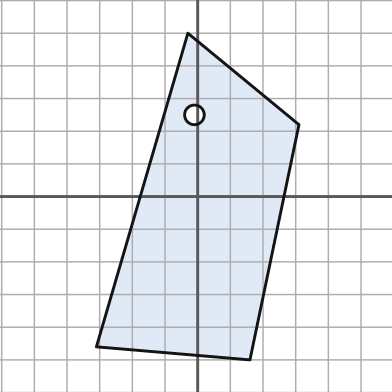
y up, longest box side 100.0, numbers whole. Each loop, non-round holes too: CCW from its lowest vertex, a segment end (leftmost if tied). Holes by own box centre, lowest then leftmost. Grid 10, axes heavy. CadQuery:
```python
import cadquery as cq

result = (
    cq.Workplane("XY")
    .moveTo(16.0, -50.0)
    .lineTo(31.0, 22.0)
    .lineTo(-3.0, 50.0)
    .lineTo(-31.0, -46.0)
    .close()
    .moveTo(-1.0, 25.0)
    .circle(3.0)
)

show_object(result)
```